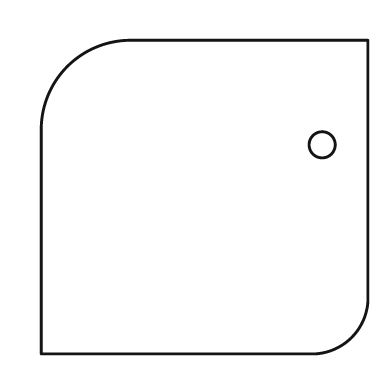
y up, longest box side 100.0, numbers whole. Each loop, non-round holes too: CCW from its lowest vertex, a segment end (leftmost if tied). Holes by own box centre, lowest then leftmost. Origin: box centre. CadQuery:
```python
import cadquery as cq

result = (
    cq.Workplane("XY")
    .moveTo(-50.0, -48.0)
    .lineTo(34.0, -48.0)
    .threePointArc((45.0, -43.0), (50.0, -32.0))
    .lineTo(50.0, 48.0)
    .lineTo(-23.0, 48.0)
    .threePointArc((-42.0, 40.0), (-50.0, 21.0))
    .close()
    .moveTo(36.0, 16.0)
    .circle(4.0)
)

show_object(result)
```